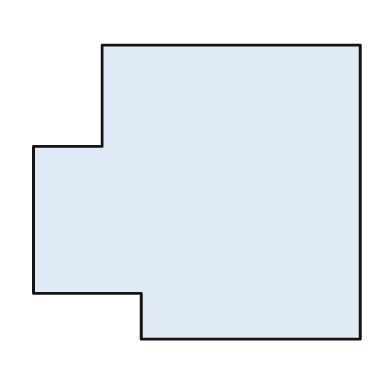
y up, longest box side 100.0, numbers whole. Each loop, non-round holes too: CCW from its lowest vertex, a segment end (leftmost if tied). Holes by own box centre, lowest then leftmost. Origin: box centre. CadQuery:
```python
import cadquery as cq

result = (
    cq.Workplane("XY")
    .moveTo(-17.0, -45.0)
    .lineTo(50.0, -45.0)
    .lineTo(50.0, 45.0)
    .lineTo(-29.0, 45.0)
    .lineTo(-29.0, 14.0)
    .lineTo(-50.0, 14.0)
    .lineTo(-50.0, -31.0)
    .lineTo(-17.0, -31.0)
    .close()
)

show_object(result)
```